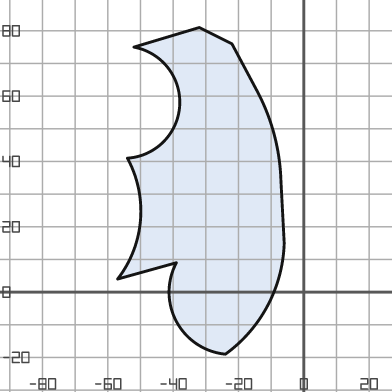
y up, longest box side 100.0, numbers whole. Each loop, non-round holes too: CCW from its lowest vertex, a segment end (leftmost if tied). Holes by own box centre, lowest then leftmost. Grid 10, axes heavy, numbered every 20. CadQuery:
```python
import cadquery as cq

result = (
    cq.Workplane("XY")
    .moveTo(-24.0, -19.0)
    .threePointArc((-11.0, -4.0), (-6.0, 15.0))
    .lineTo(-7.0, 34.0)
    .threePointArc((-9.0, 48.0), (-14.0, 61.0))
    .lineTo(-22.0, 76.0)
    .lineTo(-32.0, 81.0)
    .lineTo(-52.0, 75.0)
    .threePointArc((-38.0, 57.0), (-54.0, 41.0))
    .threePointArc((-50.0, 22.0), (-57.0, 4.0))
    .lineTo(-39.0, 9.0)
    .threePointArc((-39.0, -9.0), (-24.0, -19.0))
    .close()
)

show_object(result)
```